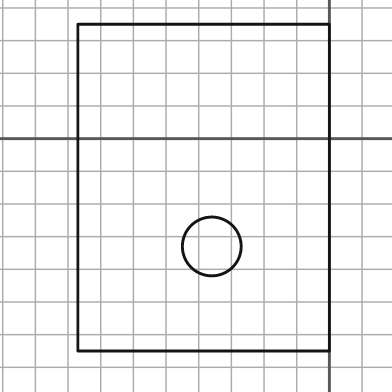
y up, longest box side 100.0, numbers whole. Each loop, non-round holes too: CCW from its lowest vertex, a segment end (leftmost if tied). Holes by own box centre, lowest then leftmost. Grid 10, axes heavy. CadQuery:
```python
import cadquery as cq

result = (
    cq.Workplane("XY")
    .moveTo(-77.0, -65.0)
    .lineTo(0.0, -65.0)
    .lineTo(0.0, 35.0)
    .lineTo(-77.0, 35.0)
    .close()
    .moveTo(-36.0, -33.0)
    .circle(9.0)
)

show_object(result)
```